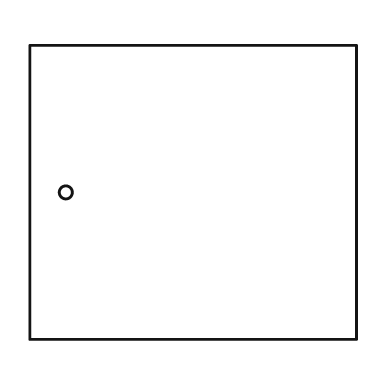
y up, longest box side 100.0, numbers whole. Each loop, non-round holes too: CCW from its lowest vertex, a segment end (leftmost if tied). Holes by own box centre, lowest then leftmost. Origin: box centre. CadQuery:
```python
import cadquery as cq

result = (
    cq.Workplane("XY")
    .moveTo(-50.0, -45.0)
    .lineTo(50.0, -45.0)
    .lineTo(50.0, 45.0)
    .lineTo(-50.0, 45.0)
    .close()
    .moveTo(-39.0, 0.0)
    .circle(2.0)
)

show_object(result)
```